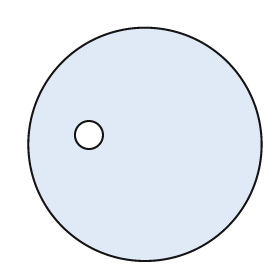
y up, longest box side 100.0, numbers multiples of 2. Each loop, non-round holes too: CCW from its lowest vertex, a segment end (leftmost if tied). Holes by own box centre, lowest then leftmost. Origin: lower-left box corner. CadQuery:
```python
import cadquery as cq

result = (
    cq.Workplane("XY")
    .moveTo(50.0, 50.0)
    .circle(50.0)
    .moveTo(26.0, 54.0)
    .circle(6.0)
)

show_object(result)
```